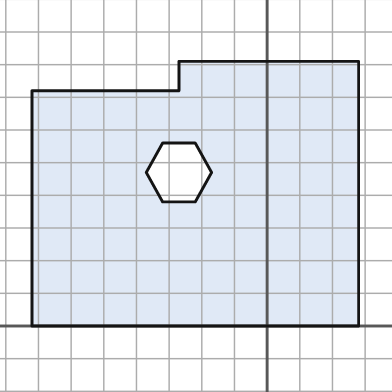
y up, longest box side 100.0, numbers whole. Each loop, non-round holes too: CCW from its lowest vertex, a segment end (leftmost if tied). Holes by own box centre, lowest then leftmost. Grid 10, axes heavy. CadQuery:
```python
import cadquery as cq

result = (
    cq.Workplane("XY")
    .moveTo(-72.0, 0.0)
    .lineTo(28.0, 0.0)
    .lineTo(28.0, 81.0)
    .lineTo(-27.0, 81.0)
    .lineTo(-27.0, 72.0)
    .lineTo(-72.0, 72.0)
    .close()
    .moveTo(-32.0, 38.0)
    .lineTo(-22.0, 38.0)
    .lineTo(-17.0, 47.0)
    .lineTo(-22.0, 56.0)
    .lineTo(-32.0, 56.0)
    .lineTo(-37.0, 47.0)
    .close()
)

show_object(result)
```